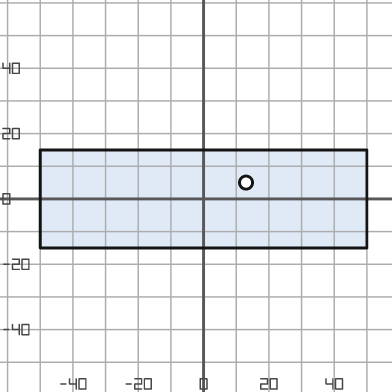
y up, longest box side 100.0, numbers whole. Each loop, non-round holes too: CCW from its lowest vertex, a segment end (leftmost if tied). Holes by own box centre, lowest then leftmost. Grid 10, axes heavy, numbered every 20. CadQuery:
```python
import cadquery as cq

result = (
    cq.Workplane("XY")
    .moveTo(-50.0, -15.0)
    .lineTo(50.0, -15.0)
    .lineTo(50.0, 15.0)
    .lineTo(-50.0, 15.0)
    .close()
    .moveTo(13.0, 5.0)
    .circle(2.0)
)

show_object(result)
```